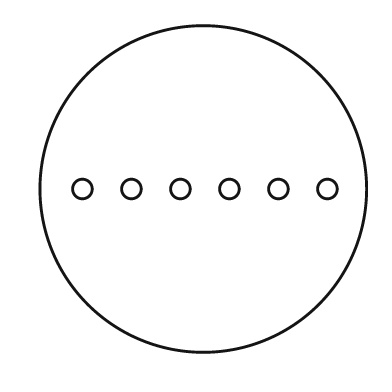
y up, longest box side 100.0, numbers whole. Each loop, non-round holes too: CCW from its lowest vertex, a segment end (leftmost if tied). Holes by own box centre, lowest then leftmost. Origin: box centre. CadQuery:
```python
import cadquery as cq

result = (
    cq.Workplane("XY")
    .moveTo(0.0, 0.0)
    .circle(50.0)
    .moveTo(-37.0, 0.0)
    .circle(3.0)
    .moveTo(-22.0, 0.0)
    .circle(3.0)
    .moveTo(-7.0, 0.0)
    .circle(3.0)
    .moveTo(8.0, 0.0)
    .circle(3.0)
    .moveTo(23.0, 0.0)
    .circle(3.0)
    .moveTo(38.0, 0.0)
    .circle(3.0)
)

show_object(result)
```